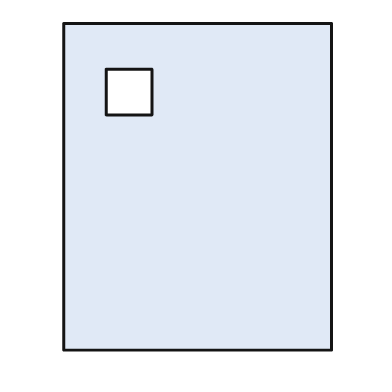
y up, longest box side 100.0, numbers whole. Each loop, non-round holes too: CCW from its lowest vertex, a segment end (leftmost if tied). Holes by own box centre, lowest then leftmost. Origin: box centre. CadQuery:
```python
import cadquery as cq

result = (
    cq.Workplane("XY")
    .moveTo(-41.0, -50.0)
    .lineTo(41.0, -50.0)
    .lineTo(41.0, 50.0)
    .lineTo(-41.0, 50.0)
    .close()
    .moveTo(-28.0, 22.0)
    .lineTo(-14.0, 22.0)
    .lineTo(-14.0, 36.0)
    .lineTo(-28.0, 36.0)
    .close()
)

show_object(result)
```